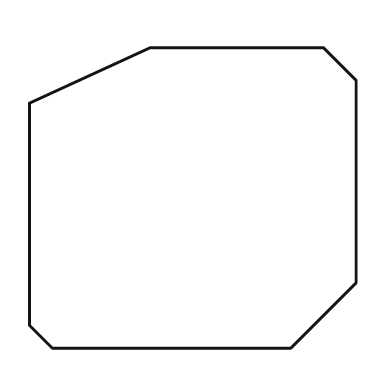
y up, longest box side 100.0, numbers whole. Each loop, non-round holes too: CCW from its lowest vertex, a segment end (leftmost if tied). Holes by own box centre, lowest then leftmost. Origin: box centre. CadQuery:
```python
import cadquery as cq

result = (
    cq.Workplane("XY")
    .moveTo(-43.0, -46.0)
    .lineTo(30.0, -46.0)
    .lineTo(50.0, -26.0)
    .lineTo(50.0, 36.0)
    .lineTo(40.0, 46.0)
    .lineTo(-13.0, 46.0)
    .lineTo(-50.0, 29.0)
    .lineTo(-50.0, -39.0)
    .close()
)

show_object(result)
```